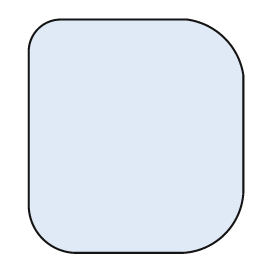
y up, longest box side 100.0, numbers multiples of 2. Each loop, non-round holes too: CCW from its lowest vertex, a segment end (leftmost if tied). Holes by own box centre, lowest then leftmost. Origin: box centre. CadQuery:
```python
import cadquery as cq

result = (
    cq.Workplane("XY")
    .moveTo(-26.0, -50.0)
    .lineTo(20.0, -50.0)
    .threePointArc((38.0, -42.0), (46.0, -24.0))
    .lineTo(46.0, 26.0)
    .threePointArc((38.0, 42.0), (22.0, 50.0))
    .lineTo(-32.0, 50.0)
    .threePointArc((-42.0, 46.0), (-46.0, 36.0))
    .lineTo(-46.0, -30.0)
    .threePointArc((-40.0, -44.0), (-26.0, -50.0))
    .close()
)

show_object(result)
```